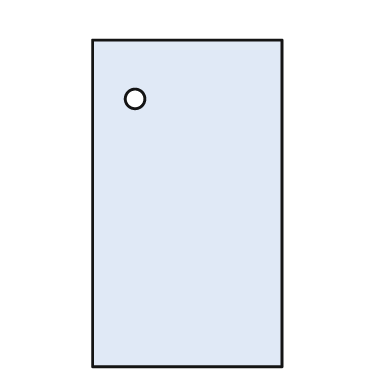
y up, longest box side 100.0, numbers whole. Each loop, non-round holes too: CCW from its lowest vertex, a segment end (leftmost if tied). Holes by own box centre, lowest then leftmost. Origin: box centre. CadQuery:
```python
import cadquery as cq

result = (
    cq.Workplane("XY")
    .moveTo(-29.0, -50.0)
    .lineTo(29.0, -50.0)
    .lineTo(29.0, 50.0)
    .lineTo(-29.0, 50.0)
    .close()
    .moveTo(-16.0, 32.0)
    .circle(3.0)
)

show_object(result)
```